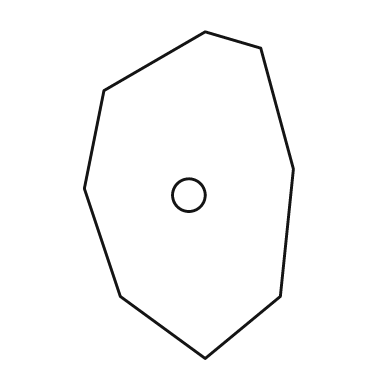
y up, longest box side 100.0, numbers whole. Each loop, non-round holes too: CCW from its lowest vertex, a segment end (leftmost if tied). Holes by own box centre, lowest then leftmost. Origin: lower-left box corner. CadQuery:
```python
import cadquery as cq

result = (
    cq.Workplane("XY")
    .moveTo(37.0, 0.0)
    .lineTo(60.0, 19.0)
    .lineTo(64.0, 58.0)
    .lineTo(54.0, 95.0)
    .lineTo(37.0, 100.0)
    .lineTo(6.0, 82.0)
    .lineTo(0.0, 52.0)
    .lineTo(11.0, 19.0)
    .close()
    .moveTo(32.0, 50.0)
    .circle(5.0)
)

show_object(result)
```